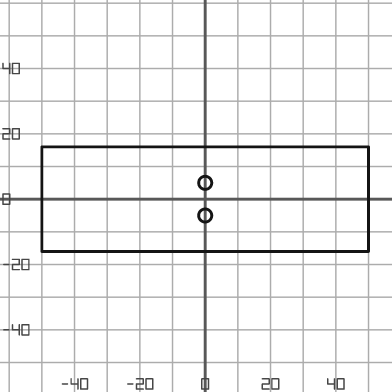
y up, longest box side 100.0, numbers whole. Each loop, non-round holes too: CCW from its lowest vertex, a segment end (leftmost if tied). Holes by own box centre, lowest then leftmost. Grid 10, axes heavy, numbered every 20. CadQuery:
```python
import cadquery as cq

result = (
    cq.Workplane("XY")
    .moveTo(-50.0, -16.0)
    .lineTo(50.0, -16.0)
    .lineTo(50.0, 16.0)
    .lineTo(-50.0, 16.0)
    .close()
    .moveTo(0.0, -5.0)
    .circle(2.0)
    .moveTo(0.0, 5.0)
    .circle(2.0)
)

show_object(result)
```